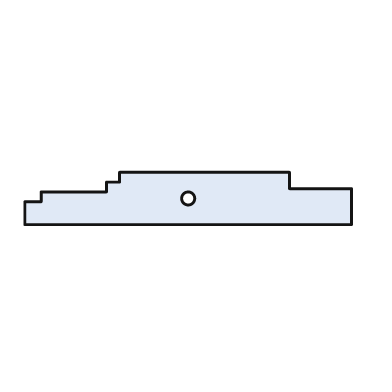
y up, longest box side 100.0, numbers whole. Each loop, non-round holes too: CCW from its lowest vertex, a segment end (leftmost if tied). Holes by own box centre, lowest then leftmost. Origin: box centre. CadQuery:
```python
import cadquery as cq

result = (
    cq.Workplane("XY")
    .moveTo(-50.0, -8.0)
    .lineTo(50.0, -8.0)
    .lineTo(50.0, 3.0)
    .lineTo(31.0, 3.0)
    .lineTo(31.0, 8.0)
    .lineTo(-21.0, 8.0)
    .lineTo(-21.0, 5.0)
    .lineTo(-25.0, 5.0)
    .lineTo(-25.0, 2.0)
    .lineTo(-45.0, 2.0)
    .lineTo(-45.0, -1.0)
    .lineTo(-50.0, -1.0)
    .close()
    .moveTo(0.0, 0.0)
    .circle(2.0)
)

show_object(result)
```